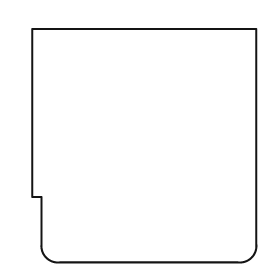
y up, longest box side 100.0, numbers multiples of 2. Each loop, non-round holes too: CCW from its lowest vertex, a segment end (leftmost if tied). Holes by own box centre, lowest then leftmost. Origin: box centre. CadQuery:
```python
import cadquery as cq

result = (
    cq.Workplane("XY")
    .moveTo(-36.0, -50.0)
    .lineTo(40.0, -50.0)
    .threePointArc((46.0, -48.0), (48.0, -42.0))
    .lineTo(48.0, 50.0)
    .lineTo(-48.0, 50.0)
    .lineTo(-48.0, -22.0)
    .lineTo(-44.0, -22.0)
    .lineTo(-44.0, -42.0)
    .threePointArc((-42.0, -48.0), (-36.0, -50.0))
    .close()
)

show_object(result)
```